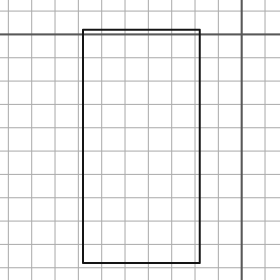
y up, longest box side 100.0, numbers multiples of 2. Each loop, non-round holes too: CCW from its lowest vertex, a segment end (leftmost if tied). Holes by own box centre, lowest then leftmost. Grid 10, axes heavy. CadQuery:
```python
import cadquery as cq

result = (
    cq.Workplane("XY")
    .moveTo(-68.0, -98.0)
    .lineTo(-18.0, -98.0)
    .lineTo(-18.0, 2.0)
    .lineTo(-68.0, 2.0)
    .close()
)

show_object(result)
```